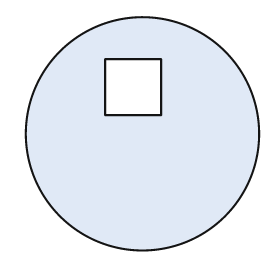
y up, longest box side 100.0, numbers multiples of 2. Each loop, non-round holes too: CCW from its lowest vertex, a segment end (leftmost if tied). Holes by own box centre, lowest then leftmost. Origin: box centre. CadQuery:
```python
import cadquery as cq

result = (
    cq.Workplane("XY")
    .moveTo(0.0, 0.0)
    .circle(50.0)
    .moveTo(-16.0, 8.0)
    .lineTo(8.0, 8.0)
    .lineTo(8.0, 32.0)
    .lineTo(-16.0, 32.0)
    .close()
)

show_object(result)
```